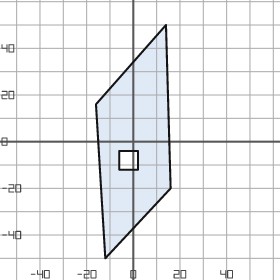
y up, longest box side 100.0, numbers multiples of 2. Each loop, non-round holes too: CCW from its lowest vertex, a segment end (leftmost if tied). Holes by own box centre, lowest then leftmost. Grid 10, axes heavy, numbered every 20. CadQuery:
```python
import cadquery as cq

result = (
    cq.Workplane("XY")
    .moveTo(-12.0, -50.0)
    .lineTo(16.0, -20.0)
    .lineTo(14.0, 50.0)
    .lineTo(-16.0, 16.0)
    .close()
    .moveTo(-6.0, -12.0)
    .lineTo(2.0, -12.0)
    .lineTo(2.0, -4.0)
    .lineTo(-6.0, -4.0)
    .close()
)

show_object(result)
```